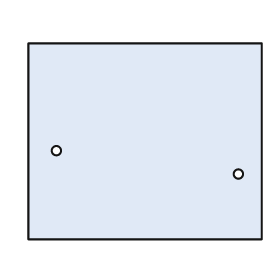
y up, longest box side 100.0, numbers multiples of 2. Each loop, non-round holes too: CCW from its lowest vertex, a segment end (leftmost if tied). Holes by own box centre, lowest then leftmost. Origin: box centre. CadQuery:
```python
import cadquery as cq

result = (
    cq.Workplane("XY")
    .moveTo(-50.0, -42.0)
    .lineTo(50.0, -42.0)
    .lineTo(50.0, 42.0)
    .lineTo(-50.0, 42.0)
    .close()
    .moveTo(40.0, -14.0)
    .circle(2.0)
    .moveTo(-38.0, -4.0)
    .circle(2.0)
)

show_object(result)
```